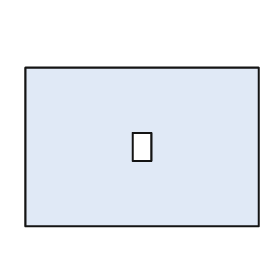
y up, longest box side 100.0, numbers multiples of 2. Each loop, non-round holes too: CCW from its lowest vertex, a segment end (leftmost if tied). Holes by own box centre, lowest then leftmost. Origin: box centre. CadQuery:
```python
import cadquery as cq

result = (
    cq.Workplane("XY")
    .moveTo(-50.0, -34.0)
    .lineTo(50.0, -34.0)
    .lineTo(50.0, 34.0)
    .lineTo(-50.0, 34.0)
    .close()
    .moveTo(-4.0, -6.0)
    .lineTo(4.0, -6.0)
    .lineTo(4.0, 6.0)
    .lineTo(-4.0, 6.0)
    .close()
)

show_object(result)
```